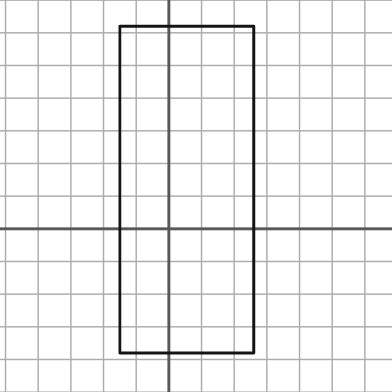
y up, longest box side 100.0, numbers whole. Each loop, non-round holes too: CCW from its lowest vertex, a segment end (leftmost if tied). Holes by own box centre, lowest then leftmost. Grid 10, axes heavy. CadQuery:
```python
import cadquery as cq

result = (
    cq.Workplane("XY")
    .moveTo(-15.0, -38.0)
    .lineTo(26.0, -38.0)
    .lineTo(26.0, 62.0)
    .lineTo(-15.0, 62.0)
    .close()
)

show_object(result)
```